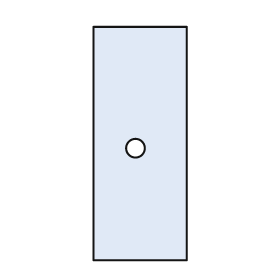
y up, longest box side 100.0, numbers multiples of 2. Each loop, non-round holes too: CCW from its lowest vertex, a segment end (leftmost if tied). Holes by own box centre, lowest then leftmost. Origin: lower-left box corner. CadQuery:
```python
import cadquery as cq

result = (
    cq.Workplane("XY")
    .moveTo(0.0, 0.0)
    .lineTo(40.0, 0.0)
    .lineTo(40.0, 100.0)
    .lineTo(0.0, 100.0)
    .close()
    .moveTo(18.0, 48.0)
    .circle(4.0)
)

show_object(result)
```